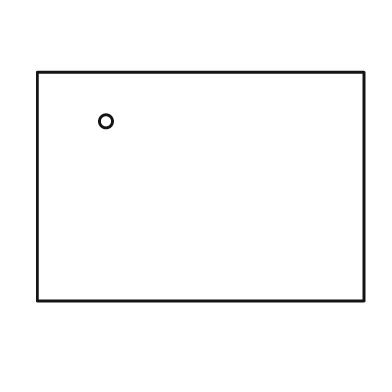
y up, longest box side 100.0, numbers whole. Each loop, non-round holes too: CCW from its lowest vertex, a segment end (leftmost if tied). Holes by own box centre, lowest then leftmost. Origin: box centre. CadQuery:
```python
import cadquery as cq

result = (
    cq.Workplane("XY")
    .moveTo(-50.0, -35.0)
    .lineTo(50.0, -35.0)
    .lineTo(50.0, 35.0)
    .lineTo(-50.0, 35.0)
    .close()
    .moveTo(-29.0, 20.0)
    .circle(2.0)
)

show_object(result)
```